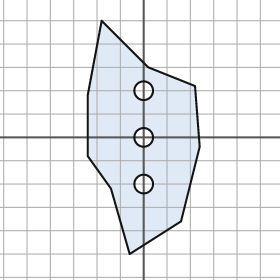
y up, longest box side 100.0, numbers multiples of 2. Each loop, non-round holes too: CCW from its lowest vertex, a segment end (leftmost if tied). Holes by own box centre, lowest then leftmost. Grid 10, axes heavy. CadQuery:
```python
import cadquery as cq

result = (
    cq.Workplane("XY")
    .moveTo(-6.0, -50.0)
    .lineTo(16.0, -36.0)
    .lineTo(24.0, -4.0)
    .lineTo(22.0, 22.0)
    .lineTo(2.0, 30.0)
    .lineTo(-18.0, 50.0)
    .lineTo(-24.0, 18.0)
    .lineTo(-24.0, -8.0)
    .lineTo(-14.0, -22.0)
    .close()
    .moveTo(0.0, -20.0)
    .circle(4.0)
    .moveTo(0.0, 0.0)
    .circle(4.0)
    .moveTo(0.0, 20.0)
    .circle(4.0)
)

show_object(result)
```